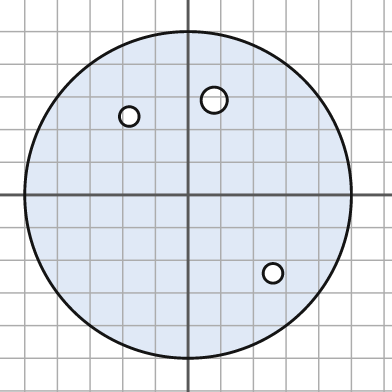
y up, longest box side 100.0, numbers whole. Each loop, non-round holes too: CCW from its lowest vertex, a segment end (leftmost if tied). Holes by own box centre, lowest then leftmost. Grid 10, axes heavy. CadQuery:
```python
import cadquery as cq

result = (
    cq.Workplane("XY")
    .moveTo(0.0, 0.0)
    .circle(50.0)
    .moveTo(26.0, -24.0)
    .circle(3.0)
    .moveTo(-18.0, 24.0)
    .circle(3.0)
    .moveTo(8.0, 29.0)
    .circle(4.0)
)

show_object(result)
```